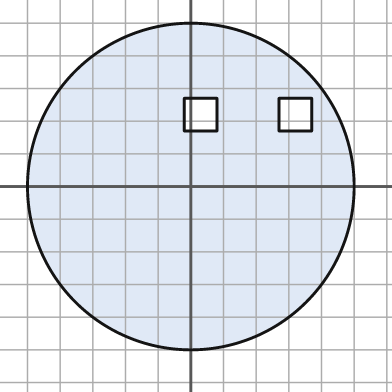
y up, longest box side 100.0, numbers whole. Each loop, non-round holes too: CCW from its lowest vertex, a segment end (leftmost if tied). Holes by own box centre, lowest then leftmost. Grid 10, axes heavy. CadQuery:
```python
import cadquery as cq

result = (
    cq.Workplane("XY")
    .moveTo(0.0, 0.0)
    .circle(50.0)
    .moveTo(-2.0, 17.0)
    .lineTo(8.0, 17.0)
    .lineTo(8.0, 27.0)
    .lineTo(-2.0, 27.0)
    .close()
    .moveTo(27.0, 17.0)
    .lineTo(37.0, 17.0)
    .lineTo(37.0, 27.0)
    .lineTo(27.0, 27.0)
    .close()
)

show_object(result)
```